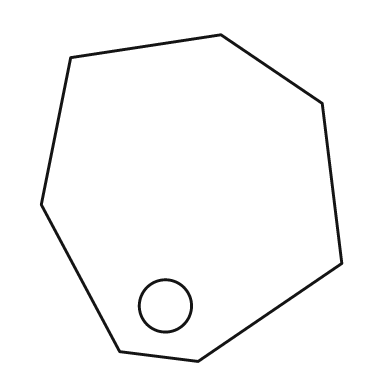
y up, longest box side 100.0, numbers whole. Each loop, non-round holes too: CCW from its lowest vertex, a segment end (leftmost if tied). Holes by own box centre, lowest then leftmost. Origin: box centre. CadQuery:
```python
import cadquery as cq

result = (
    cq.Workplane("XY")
    .moveTo(2.0, -50.0)
    .lineTo(46.0, -20.0)
    .lineTo(40.0, 29.0)
    .lineTo(9.0, 50.0)
    .lineTo(-37.0, 43.0)
    .lineTo(-46.0, -2.0)
    .lineTo(-22.0, -47.0)
    .close()
    .moveTo(-8.0, -33.0)
    .circle(8.0)
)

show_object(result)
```